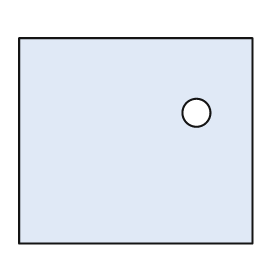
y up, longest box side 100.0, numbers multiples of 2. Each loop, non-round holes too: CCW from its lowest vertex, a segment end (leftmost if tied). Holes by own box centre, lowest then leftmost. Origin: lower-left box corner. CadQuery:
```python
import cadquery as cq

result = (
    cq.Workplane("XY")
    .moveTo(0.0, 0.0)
    .lineTo(100.0, 0.0)
    .lineTo(100.0, 88.0)
    .lineTo(0.0, 88.0)
    .close()
    .moveTo(76.0, 56.0)
    .circle(6.0)
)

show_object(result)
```